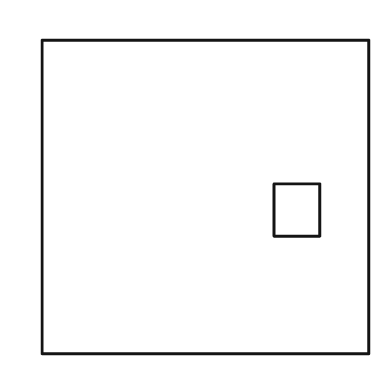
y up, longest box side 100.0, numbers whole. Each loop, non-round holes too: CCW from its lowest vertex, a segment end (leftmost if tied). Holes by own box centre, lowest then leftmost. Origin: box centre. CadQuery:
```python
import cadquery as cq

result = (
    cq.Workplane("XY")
    .moveTo(-50.0, -48.0)
    .lineTo(50.0, -48.0)
    .lineTo(50.0, 48.0)
    .lineTo(-50.0, 48.0)
    .close()
    .moveTo(21.0, -12.0)
    .lineTo(35.0, -12.0)
    .lineTo(35.0, 4.0)
    .lineTo(21.0, 4.0)
    .close()
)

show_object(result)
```